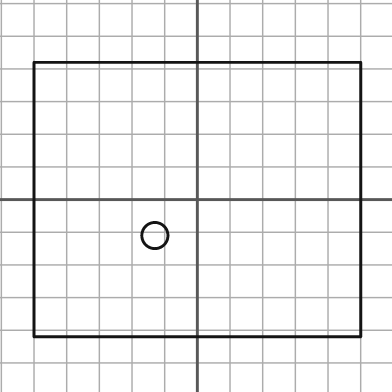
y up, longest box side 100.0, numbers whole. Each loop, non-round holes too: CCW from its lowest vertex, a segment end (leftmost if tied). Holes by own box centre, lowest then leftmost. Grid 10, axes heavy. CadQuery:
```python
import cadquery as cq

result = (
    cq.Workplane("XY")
    .moveTo(-50.0, -42.0)
    .lineTo(50.0, -42.0)
    .lineTo(50.0, 42.0)
    .lineTo(-50.0, 42.0)
    .close()
    .moveTo(-13.0, -11.0)
    .circle(4.0)
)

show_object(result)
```